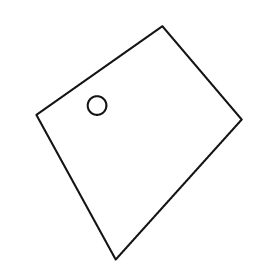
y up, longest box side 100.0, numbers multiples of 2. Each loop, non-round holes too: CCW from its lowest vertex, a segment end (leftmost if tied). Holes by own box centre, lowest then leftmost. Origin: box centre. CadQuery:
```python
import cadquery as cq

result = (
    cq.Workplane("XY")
    .moveTo(-10.0, -50.0)
    .lineTo(44.0, 10.0)
    .lineTo(10.0, 50.0)
    .lineTo(-44.0, 12.0)
    .close()
    .moveTo(-18.0, 16.0)
    .circle(4.0)
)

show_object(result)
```